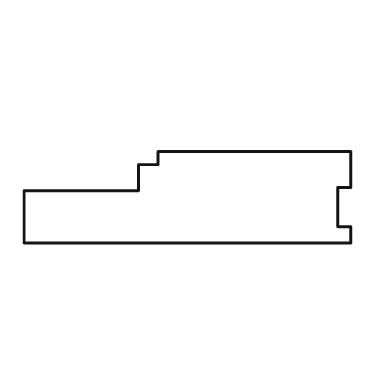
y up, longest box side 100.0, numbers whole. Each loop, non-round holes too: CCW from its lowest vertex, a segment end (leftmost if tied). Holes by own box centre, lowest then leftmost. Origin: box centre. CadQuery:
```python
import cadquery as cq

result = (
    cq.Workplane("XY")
    .moveTo(-50.0, -14.0)
    .lineTo(50.0, -14.0)
    .lineTo(50.0, -9.0)
    .lineTo(46.0, -9.0)
    .lineTo(46.0, 3.0)
    .lineTo(50.0, 3.0)
    .lineTo(50.0, 14.0)
    .lineTo(-9.0, 14.0)
    .lineTo(-9.0, 10.0)
    .lineTo(-15.0, 10.0)
    .lineTo(-15.0, 2.0)
    .lineTo(-50.0, 2.0)
    .close()
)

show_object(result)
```